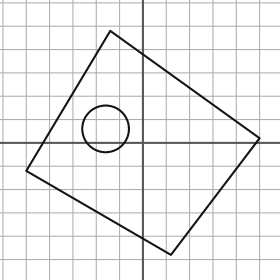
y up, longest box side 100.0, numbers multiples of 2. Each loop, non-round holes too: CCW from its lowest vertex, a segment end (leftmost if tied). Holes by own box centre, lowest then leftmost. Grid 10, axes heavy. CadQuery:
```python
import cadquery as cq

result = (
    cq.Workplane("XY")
    .moveTo(12.0, -48.0)
    .lineTo(50.0, 2.0)
    .lineTo(-14.0, 48.0)
    .lineTo(-50.0, -12.0)
    .close()
    .moveTo(-16.0, 6.0)
    .circle(10.0)
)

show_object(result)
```